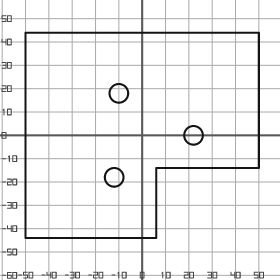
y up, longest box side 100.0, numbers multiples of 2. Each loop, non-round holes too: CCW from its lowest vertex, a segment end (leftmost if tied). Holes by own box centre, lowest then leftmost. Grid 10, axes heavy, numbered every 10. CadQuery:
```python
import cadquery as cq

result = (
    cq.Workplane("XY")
    .moveTo(-50.0, -44.0)
    .lineTo(6.0, -44.0)
    .lineTo(6.0, -14.0)
    .lineTo(50.0, -14.0)
    .lineTo(50.0, 44.0)
    .lineTo(-50.0, 44.0)
    .close()
    .moveTo(-12.0, -18.0)
    .circle(4.0)
    .moveTo(22.0, 0.0)
    .circle(4.0)
    .moveTo(-10.0, 18.0)
    .circle(4.0)
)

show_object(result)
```